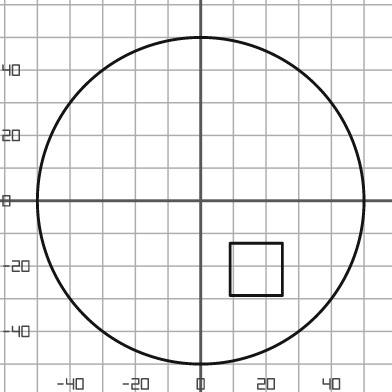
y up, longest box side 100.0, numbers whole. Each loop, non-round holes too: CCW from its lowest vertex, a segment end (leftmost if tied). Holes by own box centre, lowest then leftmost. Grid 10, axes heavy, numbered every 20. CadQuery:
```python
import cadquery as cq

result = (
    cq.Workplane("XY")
    .moveTo(0.0, 0.0)
    .circle(50.0)
    .moveTo(9.0, -29.0)
    .lineTo(25.0, -29.0)
    .lineTo(25.0, -13.0)
    .lineTo(9.0, -13.0)
    .close()
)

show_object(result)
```